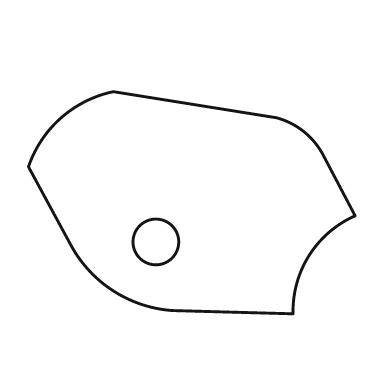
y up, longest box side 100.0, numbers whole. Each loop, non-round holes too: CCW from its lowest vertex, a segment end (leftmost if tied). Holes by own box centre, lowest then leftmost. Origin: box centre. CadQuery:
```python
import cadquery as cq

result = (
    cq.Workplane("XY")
    .moveTo(31.0, -34.0)
    .threePointArc((36.0, -16.0), (50.0, -4.0))
    .lineTo(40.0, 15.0)
    .threePointArc((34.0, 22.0), (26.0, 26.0))
    .lineTo(-24.0, 34.0)
    .threePointArc((-40.0, 26.0), (-50.0, 11.0))
    .lineTo(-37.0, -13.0)
    .threePointArc((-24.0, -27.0), (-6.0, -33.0))
    .close()
    .moveTo(-11.0, -12.0)
    .circle(7.0)
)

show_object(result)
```